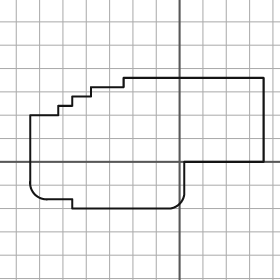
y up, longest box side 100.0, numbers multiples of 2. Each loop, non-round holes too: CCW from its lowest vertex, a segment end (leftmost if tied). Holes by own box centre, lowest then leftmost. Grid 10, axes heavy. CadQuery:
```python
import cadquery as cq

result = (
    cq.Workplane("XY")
    .moveTo(-46.0, -20.0)
    .lineTo(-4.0, -20.0)
    .threePointArc((0.0, -18.0), (2.0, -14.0))
    .lineTo(2.0, 0.0)
    .lineTo(36.0, 0.0)
    .lineTo(36.0, 36.0)
    .lineTo(-24.0, 36.0)
    .lineTo(-24.0, 32.0)
    .lineTo(-38.0, 32.0)
    .lineTo(-38.0, 28.0)
    .lineTo(-46.0, 28.0)
    .lineTo(-46.0, 24.0)
    .lineTo(-52.0, 24.0)
    .lineTo(-52.0, 20.0)
    .lineTo(-64.0, 20.0)
    .lineTo(-64.0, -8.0)
    .threePointArc((-62.0, -14.0), (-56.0, -16.0))
    .lineTo(-46.0, -16.0)
    .close()
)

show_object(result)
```